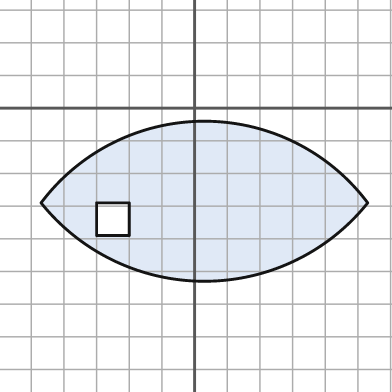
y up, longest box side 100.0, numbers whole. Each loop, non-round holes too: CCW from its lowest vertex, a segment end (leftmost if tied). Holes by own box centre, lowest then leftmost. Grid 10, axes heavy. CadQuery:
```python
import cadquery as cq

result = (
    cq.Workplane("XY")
    .moveTo(-47.0, -29.0)
    .threePointArc((3.0, -53.0), (53.0, -29.0))
    .threePointArc((3.0, -4.0), (-47.0, -29.0))
    .close()
    .moveTo(-30.0, -39.0)
    .lineTo(-20.0, -39.0)
    .lineTo(-20.0, -29.0)
    .lineTo(-30.0, -29.0)
    .close()
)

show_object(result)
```